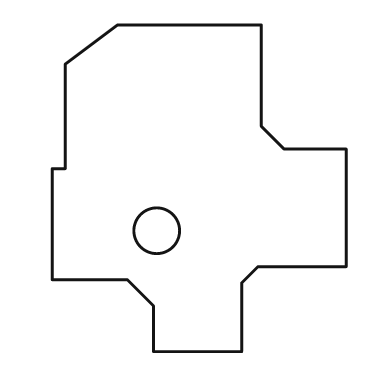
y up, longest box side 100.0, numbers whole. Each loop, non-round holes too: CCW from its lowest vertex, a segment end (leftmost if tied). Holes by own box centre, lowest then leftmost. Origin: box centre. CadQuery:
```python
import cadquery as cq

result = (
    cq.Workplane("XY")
    .moveTo(-14.0, -50.0)
    .lineTo(13.0, -50.0)
    .lineTo(13.0, -29.0)
    .lineTo(18.0, -24.0)
    .lineTo(45.0, -24.0)
    .lineTo(45.0, 12.0)
    .lineTo(26.0, 12.0)
    .lineTo(19.0, 19.0)
    .lineTo(19.0, 50.0)
    .lineTo(-25.0, 50.0)
    .lineTo(-41.0, 38.0)
    .lineTo(-41.0, 6.0)
    .lineTo(-45.0, 6.0)
    .lineTo(-45.0, -28.0)
    .lineTo(-22.0, -28.0)
    .lineTo(-14.0, -36.0)
    .close()
    .moveTo(-13.0, -13.0)
    .circle(7.0)
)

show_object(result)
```